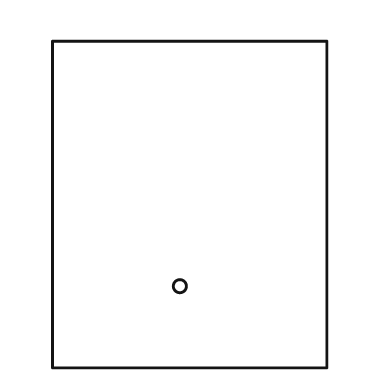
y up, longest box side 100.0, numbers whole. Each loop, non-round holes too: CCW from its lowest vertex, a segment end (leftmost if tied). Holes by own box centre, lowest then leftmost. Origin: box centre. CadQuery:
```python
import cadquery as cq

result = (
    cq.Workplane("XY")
    .moveTo(-42.0, -50.0)
    .lineTo(42.0, -50.0)
    .lineTo(42.0, 50.0)
    .lineTo(-42.0, 50.0)
    .close()
    .moveTo(-3.0, -25.0)
    .circle(2.0)
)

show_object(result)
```